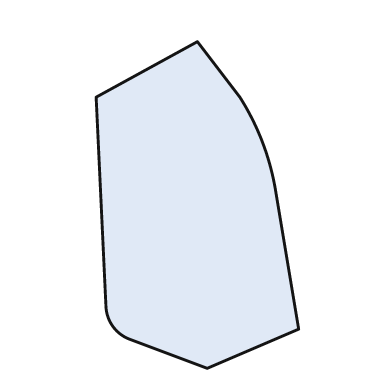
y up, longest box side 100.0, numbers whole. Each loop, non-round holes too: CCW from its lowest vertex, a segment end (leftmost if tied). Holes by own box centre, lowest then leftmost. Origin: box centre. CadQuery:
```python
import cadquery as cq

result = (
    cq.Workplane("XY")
    .moveTo(3.0, -50.0)
    .lineTo(31.0, -38.0)
    .lineTo(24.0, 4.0)
    .threePointArc((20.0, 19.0), (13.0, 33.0))
    .lineTo(0.0, 50.0)
    .lineTo(-31.0, 33.0)
    .lineTo(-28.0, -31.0)
    .threePointArc((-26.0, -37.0), (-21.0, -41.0))
    .close()
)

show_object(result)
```